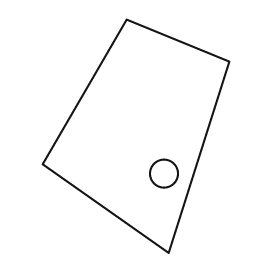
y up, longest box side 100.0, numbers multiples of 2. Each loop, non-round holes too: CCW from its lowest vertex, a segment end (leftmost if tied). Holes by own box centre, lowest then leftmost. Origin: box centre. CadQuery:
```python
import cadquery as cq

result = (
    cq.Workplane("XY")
    .moveTo(14.0, -50.0)
    .lineTo(40.0, 32.0)
    .lineTo(-4.0, 50.0)
    .lineTo(-40.0, -12.0)
    .close()
    .moveTo(12.0, -16.0)
    .circle(6.0)
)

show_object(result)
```